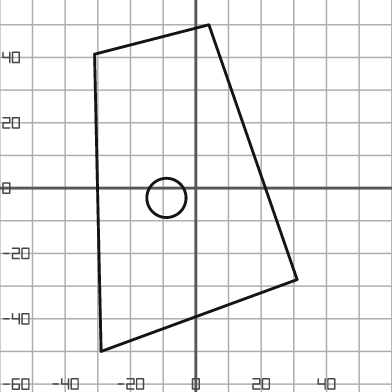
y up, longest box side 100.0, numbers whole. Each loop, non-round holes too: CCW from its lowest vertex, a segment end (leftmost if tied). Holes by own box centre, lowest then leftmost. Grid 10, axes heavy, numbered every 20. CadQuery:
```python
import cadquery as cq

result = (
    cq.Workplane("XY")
    .moveTo(-29.0, -50.0)
    .lineTo(31.0, -28.0)
    .lineTo(4.0, 50.0)
    .lineTo(-31.0, 41.0)
    .close()
    .moveTo(-9.0, -3.0)
    .circle(6.0)
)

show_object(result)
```